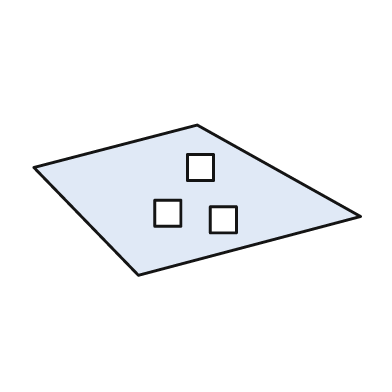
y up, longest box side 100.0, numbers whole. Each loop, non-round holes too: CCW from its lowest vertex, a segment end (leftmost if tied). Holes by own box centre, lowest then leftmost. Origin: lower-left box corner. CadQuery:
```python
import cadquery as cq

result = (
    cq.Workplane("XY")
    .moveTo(32.0, 0.0)
    .lineTo(100.0, 18.0)
    .lineTo(50.0, 46.0)
    .lineTo(0.0, 33.0)
    .close()
    .moveTo(54.0, 13.0)
    .lineTo(62.0, 13.0)
    .lineTo(62.0, 21.0)
    .lineTo(54.0, 21.0)
    .close()
    .moveTo(37.0, 15.0)
    .lineTo(45.0, 15.0)
    .lineTo(45.0, 23.0)
    .lineTo(37.0, 23.0)
    .close()
    .moveTo(47.0, 29.0)
    .lineTo(55.0, 29.0)
    .lineTo(55.0, 37.0)
    .lineTo(47.0, 37.0)
    .close()
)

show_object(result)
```